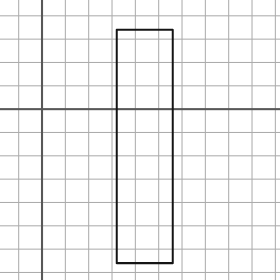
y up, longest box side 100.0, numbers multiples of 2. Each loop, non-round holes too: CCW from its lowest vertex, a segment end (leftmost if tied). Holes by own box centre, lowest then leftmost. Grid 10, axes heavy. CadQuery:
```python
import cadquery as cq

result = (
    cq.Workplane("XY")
    .moveTo(32.0, -66.0)
    .lineTo(56.0, -66.0)
    .lineTo(56.0, 34.0)
    .lineTo(32.0, 34.0)
    .close()
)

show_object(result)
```